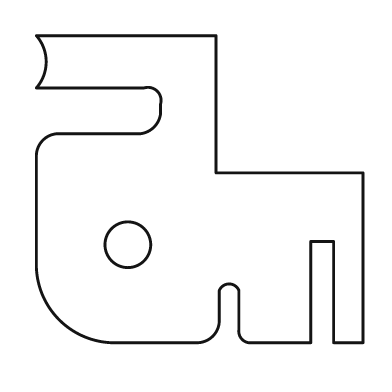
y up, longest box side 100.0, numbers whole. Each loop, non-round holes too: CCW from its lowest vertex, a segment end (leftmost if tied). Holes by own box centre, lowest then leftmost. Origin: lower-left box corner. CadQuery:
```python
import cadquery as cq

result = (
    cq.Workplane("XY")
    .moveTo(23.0, 0.0)
    .lineTo(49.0, 0.0)
    .threePointArc((54.0, 2.0), (56.0, 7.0))
    .lineTo(56.0, 16.0)
    .threePointArc((59.0, 18.0), (62.0, 16.0))
    .lineTo(62.0, 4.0)
    .threePointArc((63.0, 1.0), (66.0, 0.0))
    .lineTo(84.0, 0.0)
    .lineTo(84.0, 31.0)
    .lineTo(91.0, 31.0)
    .lineTo(91.0, 0.0)
    .lineTo(100.0, 0.0)
    .lineTo(100.0, 52.0)
    .lineTo(55.0, 52.0)
    .lineTo(55.0, 94.0)
    .lineTo(0.0, 94.0)
    .threePointArc((3.0, 86.0), (0.0, 78.0))
    .lineTo(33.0, 78.0)
    .threePointArc((37.0, 77.0), (38.0, 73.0))
    .lineTo(38.0, 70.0)
    .threePointArc((36.0, 66.0), (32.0, 64.0))
    .lineTo(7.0, 64.0)
    .threePointArc((2.0, 62.0), (0.0, 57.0))
    .lineTo(0.0, 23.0)
    .threePointArc((7.0, 7.0), (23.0, 0.0))
    .close()
    .moveTo(28.0, 30.0)
    .circle(7.0)
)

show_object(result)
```